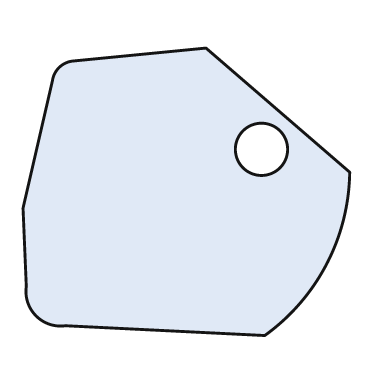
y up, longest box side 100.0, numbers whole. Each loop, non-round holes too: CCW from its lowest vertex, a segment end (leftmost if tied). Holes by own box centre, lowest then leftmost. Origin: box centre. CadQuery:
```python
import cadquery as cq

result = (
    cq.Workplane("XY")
    .moveTo(24.0, -44.0)
    .threePointArc((43.0, -22.0), (50.0, 6.0))
    .lineTo(6.0, 44.0)
    .lineTo(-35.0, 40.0)
    .threePointArc((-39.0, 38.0), (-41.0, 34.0))
    .lineTo(-50.0, -5.0)
    .lineTo(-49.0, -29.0)
    .threePointArc((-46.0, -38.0), (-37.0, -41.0))
    .close()
    .moveTo(23.0, 13.0)
    .circle(8.0)
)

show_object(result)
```